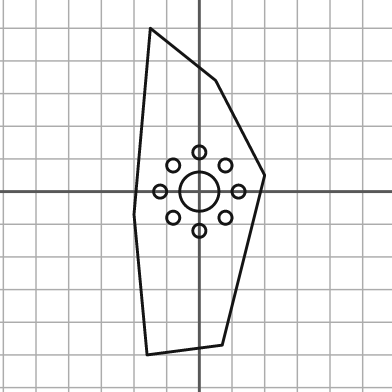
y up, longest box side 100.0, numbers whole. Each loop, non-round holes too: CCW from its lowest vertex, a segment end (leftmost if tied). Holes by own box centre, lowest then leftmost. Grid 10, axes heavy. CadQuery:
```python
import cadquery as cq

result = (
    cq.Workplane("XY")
    .moveTo(-16.0, -50.0)
    .lineTo(7.0, -47.0)
    .lineTo(20.0, 5.0)
    .lineTo(5.0, 34.0)
    .lineTo(-15.0, 50.0)
    .lineTo(-20.0, -7.0)
    .close()
    .moveTo(0.0, -12.0)
    .circle(2.0)
    .moveTo(-8.0, -8.0)
    .circle(2.0)
    .moveTo(8.0, -8.0)
    .circle(2.0)
    .moveTo(-12.0, 0.0)
    .circle(2.0)
    .moveTo(0.0, 0.0)
    .circle(6.0)
    .moveTo(12.0, 0.0)
    .circle(2.0)
    .moveTo(-8.0, 8.0)
    .circle(2.0)
    .moveTo(8.0, 8.0)
    .circle(2.0)
    .moveTo(0.0, 12.0)
    .circle(2.0)
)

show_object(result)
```